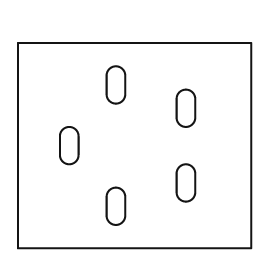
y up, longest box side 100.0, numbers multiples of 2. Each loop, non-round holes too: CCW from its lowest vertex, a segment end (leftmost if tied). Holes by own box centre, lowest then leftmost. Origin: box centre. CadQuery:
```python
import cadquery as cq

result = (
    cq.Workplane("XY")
    .moveTo(-50.0, -44.0)
    .lineTo(50.0, -44.0)
    .lineTo(50.0, 44.0)
    .lineTo(-50.0, 44.0)
    .close()
    .moveTo(-12.0, -30.0)
    .threePointArc((-8.0, -34.0), (-4.0, -30.0))
    .lineTo(-4.0, -22.0)
    .threePointArc((-8.0, -18.0), (-12.0, -22.0))
    .close()
    .moveTo(18.0, -20.0)
    .threePointArc((22.0, -24.0), (26.0, -20.0))
    .lineTo(26.0, -12.0)
    .threePointArc((22.0, -8.0), (18.0, -12.0))
    .close()
    .moveTo(-32.0, -4.0)
    .threePointArc((-28.0, -8.0), (-24.0, -4.0))
    .lineTo(-24.0, 4.0)
    .threePointArc((-28.0, 8.0), (-32.0, 4.0))
    .close()
    .moveTo(18.0, 12.0)
    .threePointArc((22.0, 8.0), (26.0, 12.0))
    .lineTo(26.0, 20.0)
    .threePointArc((22.0, 24.0), (18.0, 20.0))
    .close()
    .moveTo(-12.0, 22.0)
    .threePointArc((-8.0, 18.0), (-4.0, 22.0))
    .lineTo(-4.0, 30.0)
    .threePointArc((-8.0, 34.0), (-12.0, 30.0))
    .close()
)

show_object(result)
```